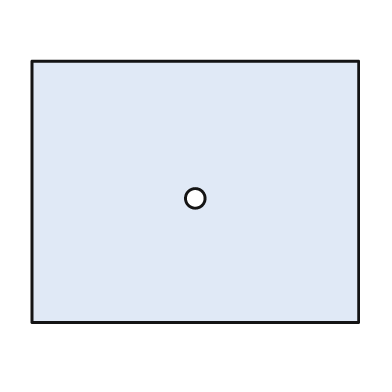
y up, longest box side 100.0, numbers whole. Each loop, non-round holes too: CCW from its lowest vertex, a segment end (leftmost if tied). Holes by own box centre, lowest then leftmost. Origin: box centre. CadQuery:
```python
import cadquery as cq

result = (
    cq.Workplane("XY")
    .moveTo(-50.0, -40.0)
    .lineTo(50.0, -40.0)
    .lineTo(50.0, 40.0)
    .lineTo(-50.0, 40.0)
    .close()
    .moveTo(0.0, -2.0)
    .circle(3.0)
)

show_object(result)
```